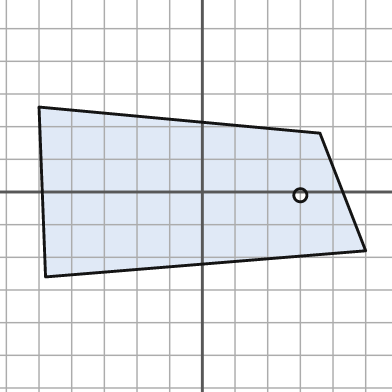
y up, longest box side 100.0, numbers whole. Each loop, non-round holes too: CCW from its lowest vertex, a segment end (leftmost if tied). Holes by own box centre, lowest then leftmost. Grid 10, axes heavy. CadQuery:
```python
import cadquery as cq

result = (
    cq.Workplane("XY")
    .moveTo(-48.0, -26.0)
    .lineTo(50.0, -18.0)
    .lineTo(36.0, 18.0)
    .lineTo(-50.0, 26.0)
    .close()
    .moveTo(30.0, -1.0)
    .circle(2.0)
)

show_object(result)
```